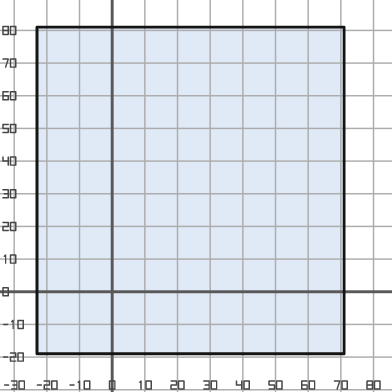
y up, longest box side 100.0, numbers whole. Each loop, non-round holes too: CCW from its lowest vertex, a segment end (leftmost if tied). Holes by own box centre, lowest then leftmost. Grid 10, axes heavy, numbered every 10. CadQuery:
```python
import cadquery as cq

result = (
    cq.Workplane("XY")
    .moveTo(-23.0, -19.0)
    .lineTo(71.0, -19.0)
    .lineTo(71.0, 81.0)
    .lineTo(-23.0, 81.0)
    .close()
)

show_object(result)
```